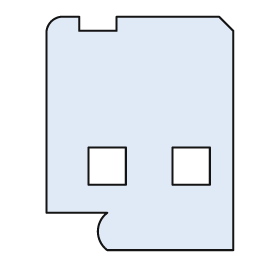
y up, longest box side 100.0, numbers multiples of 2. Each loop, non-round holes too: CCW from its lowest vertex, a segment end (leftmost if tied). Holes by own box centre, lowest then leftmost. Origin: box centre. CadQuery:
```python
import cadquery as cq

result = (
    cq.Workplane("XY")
    .moveTo(-14.0, -50.0)
    .lineTo(40.0, -50.0)
    .lineTo(40.0, 44.0)
    .lineTo(34.0, 50.0)
    .lineTo(-10.0, 50.0)
    .lineTo(-10.0, 44.0)
    .lineTo(-26.0, 44.0)
    .lineTo(-26.0, 50.0)
    .lineTo(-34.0, 50.0)
    .threePointArc((-38.0, 48.0), (-40.0, 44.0))
    .lineTo(-40.0, -34.0)
    .lineTo(-14.0, -34.0)
    .threePointArc((-18.0, -42.0), (-14.0, -50.0))
    .close()
    .moveTo(-22.0, -22.0)
    .lineTo(-6.0, -22.0)
    .lineTo(-6.0, -6.0)
    .lineTo(-22.0, -6.0)
    .close()
    .moveTo(14.0, -22.0)
    .lineTo(30.0, -22.0)
    .lineTo(30.0, -6.0)
    .lineTo(14.0, -6.0)
    .close()
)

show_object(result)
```